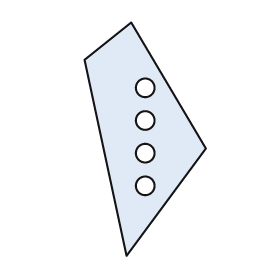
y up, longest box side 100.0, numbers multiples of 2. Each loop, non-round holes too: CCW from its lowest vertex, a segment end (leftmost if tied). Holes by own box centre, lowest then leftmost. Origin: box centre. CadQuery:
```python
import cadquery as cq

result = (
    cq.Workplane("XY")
    .moveTo(-8.0, -50.0)
    .lineTo(26.0, -4.0)
    .lineTo(-6.0, 50.0)
    .lineTo(-26.0, 34.0)
    .close()
    .moveTo(0.0, -20.0)
    .circle(4.0)
    .moveTo(0.0, -6.0)
    .circle(4.0)
    .moveTo(0.0, 8.0)
    .circle(4.0)
    .moveTo(0.0, 22.0)
    .circle(4.0)
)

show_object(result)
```